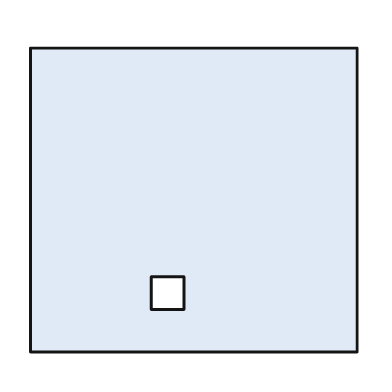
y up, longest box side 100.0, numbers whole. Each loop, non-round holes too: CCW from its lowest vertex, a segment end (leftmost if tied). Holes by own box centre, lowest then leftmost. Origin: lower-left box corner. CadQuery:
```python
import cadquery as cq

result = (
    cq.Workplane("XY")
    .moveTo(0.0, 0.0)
    .lineTo(100.0, 0.0)
    .lineTo(100.0, 93.0)
    .lineTo(0.0, 93.0)
    .close()
    .moveTo(37.0, 13.0)
    .lineTo(47.0, 13.0)
    .lineTo(47.0, 23.0)
    .lineTo(37.0, 23.0)
    .close()
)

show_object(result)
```